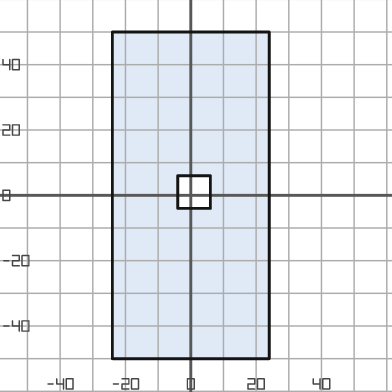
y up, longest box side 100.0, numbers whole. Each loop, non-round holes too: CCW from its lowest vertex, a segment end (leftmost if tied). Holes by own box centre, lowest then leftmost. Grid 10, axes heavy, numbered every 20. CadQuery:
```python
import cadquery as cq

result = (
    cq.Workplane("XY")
    .moveTo(-24.0, -50.0)
    .lineTo(24.0, -50.0)
    .lineTo(24.0, 50.0)
    .lineTo(-24.0, 50.0)
    .close()
    .moveTo(-4.0, -4.0)
    .lineTo(6.0, -4.0)
    .lineTo(6.0, 6.0)
    .lineTo(-4.0, 6.0)
    .close()
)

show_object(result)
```